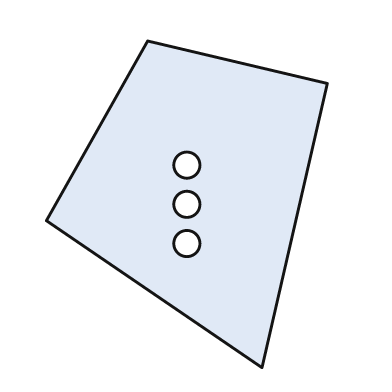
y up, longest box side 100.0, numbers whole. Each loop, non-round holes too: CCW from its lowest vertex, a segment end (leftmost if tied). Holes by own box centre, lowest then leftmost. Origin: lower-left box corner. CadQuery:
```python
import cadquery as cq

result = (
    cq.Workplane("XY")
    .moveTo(66.0, 0.0)
    .lineTo(86.0, 87.0)
    .lineTo(31.0, 100.0)
    .lineTo(0.0, 45.0)
    .close()
    .moveTo(43.0, 38.0)
    .circle(4.0)
    .moveTo(43.0, 50.0)
    .circle(4.0)
    .moveTo(43.0, 62.0)
    .circle(4.0)
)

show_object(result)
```